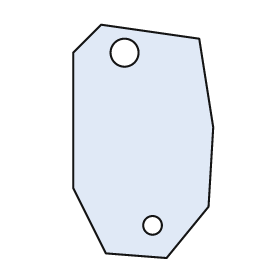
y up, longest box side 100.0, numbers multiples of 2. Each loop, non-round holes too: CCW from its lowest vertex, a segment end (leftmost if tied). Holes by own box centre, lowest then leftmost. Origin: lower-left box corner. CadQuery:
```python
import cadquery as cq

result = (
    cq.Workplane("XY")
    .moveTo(40.0, 0.0)
    .lineTo(58.0, 22.0)
    .lineTo(60.0, 56.0)
    .lineTo(54.0, 94.0)
    .lineTo(12.0, 100.0)
    .lineTo(0.0, 88.0)
    .lineTo(0.0, 30.0)
    .lineTo(14.0, 2.0)
    .close()
    .moveTo(34.0, 14.0)
    .circle(4.0)
    .moveTo(22.0, 88.0)
    .circle(6.0)
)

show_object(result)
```